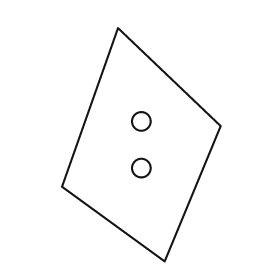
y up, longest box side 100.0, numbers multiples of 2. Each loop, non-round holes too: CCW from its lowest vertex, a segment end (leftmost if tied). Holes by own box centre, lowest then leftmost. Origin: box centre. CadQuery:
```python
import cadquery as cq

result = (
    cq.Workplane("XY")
    .moveTo(10.0, -50.0)
    .lineTo(34.0, 8.0)
    .lineTo(-10.0, 50.0)
    .lineTo(-34.0, -18.0)
    .close()
    .moveTo(0.0, -10.0)
    .circle(4.0)
    .moveTo(0.0, 10.0)
    .circle(4.0)
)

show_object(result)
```